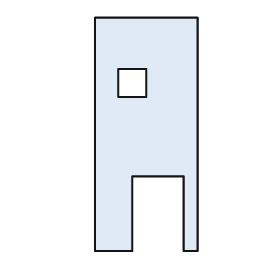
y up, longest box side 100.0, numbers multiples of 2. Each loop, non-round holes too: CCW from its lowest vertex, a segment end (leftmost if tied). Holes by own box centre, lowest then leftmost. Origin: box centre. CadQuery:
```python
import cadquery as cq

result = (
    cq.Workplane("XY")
    .moveTo(-22.0, -50.0)
    .lineTo(-6.0, -50.0)
    .lineTo(-6.0, -18.0)
    .lineTo(16.0, -18.0)
    .lineTo(16.0, -50.0)
    .lineTo(22.0, -50.0)
    .lineTo(22.0, 50.0)
    .lineTo(-22.0, 50.0)
    .close()
    .moveTo(-12.0, 16.0)
    .lineTo(0.0, 16.0)
    .lineTo(0.0, 28.0)
    .lineTo(-12.0, 28.0)
    .close()
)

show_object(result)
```